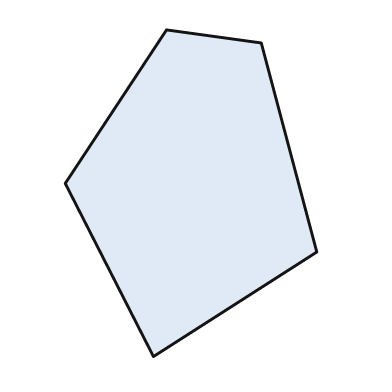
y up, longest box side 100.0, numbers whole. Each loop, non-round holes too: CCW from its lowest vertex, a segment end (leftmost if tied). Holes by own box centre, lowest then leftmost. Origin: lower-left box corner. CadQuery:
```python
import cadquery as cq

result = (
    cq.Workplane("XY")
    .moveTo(27.0, 0.0)
    .lineTo(77.0, 32.0)
    .lineTo(60.0, 96.0)
    .lineTo(31.0, 100.0)
    .lineTo(0.0, 53.0)
    .close()
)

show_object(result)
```